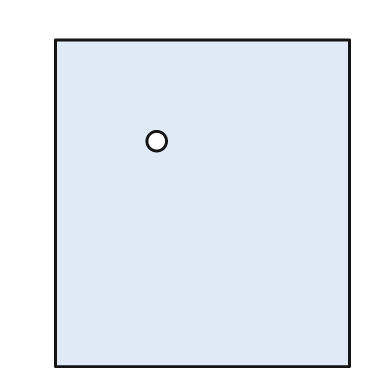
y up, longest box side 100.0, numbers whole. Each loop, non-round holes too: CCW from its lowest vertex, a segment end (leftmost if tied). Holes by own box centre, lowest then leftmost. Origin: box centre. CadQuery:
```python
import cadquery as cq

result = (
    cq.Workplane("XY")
    .moveTo(-45.0, -50.0)
    .lineTo(45.0, -50.0)
    .lineTo(45.0, 50.0)
    .lineTo(-45.0, 50.0)
    .close()
    .moveTo(-14.0, 19.0)
    .circle(3.0)
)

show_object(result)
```